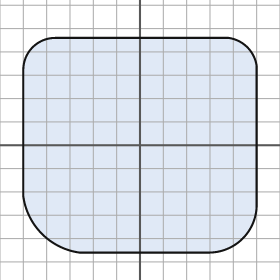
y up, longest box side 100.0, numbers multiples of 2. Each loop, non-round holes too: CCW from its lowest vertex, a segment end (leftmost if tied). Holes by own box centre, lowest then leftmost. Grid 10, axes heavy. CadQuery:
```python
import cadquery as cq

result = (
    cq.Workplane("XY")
    .moveTo(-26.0, -46.0)
    .lineTo(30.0, -46.0)
    .threePointArc((44.0, -40.0), (50.0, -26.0))
    .lineTo(50.0, 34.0)
    .threePointArc((46.0, 42.0), (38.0, 46.0))
    .lineTo(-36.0, 46.0)
    .threePointArc((-46.0, 42.0), (-50.0, 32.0))
    .lineTo(-50.0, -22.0)
    .threePointArc((-42.0, -38.0), (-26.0, -46.0))
    .close()
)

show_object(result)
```